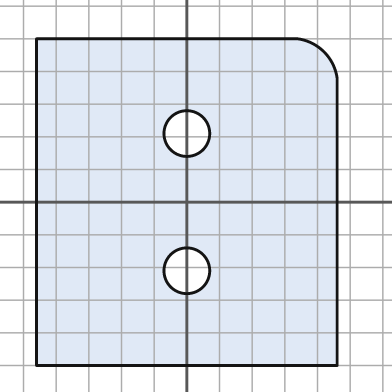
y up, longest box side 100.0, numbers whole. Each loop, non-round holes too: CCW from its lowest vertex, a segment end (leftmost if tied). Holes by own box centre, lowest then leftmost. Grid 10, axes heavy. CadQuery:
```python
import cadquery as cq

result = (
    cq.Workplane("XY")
    .moveTo(-46.0, -50.0)
    .lineTo(46.0, -50.0)
    .lineTo(46.0, 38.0)
    .threePointArc((42.0, 46.0), (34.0, 50.0))
    .lineTo(-46.0, 50.0)
    .close()
    .moveTo(0.0, -21.0)
    .circle(7.0)
    .moveTo(0.0, 21.0)
    .circle(7.0)
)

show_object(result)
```